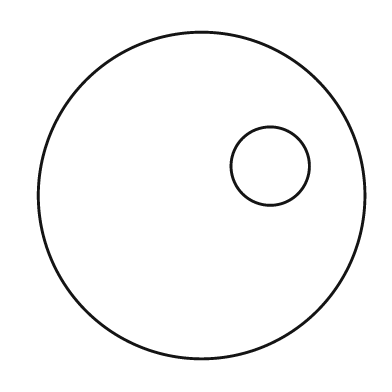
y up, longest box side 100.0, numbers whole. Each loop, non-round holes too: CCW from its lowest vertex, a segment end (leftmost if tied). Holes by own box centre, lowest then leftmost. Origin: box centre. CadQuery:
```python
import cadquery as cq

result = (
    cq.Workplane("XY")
    .moveTo(0.0, 0.0)
    .circle(50.0)
    .moveTo(21.0, 9.0)
    .circle(12.0)
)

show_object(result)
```